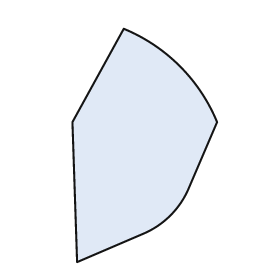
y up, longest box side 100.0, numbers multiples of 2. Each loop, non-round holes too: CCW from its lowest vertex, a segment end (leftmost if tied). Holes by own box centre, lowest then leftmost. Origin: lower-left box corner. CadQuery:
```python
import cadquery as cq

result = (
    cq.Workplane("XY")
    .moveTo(2.0, 0.0)
    .lineTo(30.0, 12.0)
    .threePointArc((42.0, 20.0), (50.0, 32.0))
    .lineTo(62.0, 60.0)
    .threePointArc((46.0, 84.0), (22.0, 100.0))
    .lineTo(0.0, 60.0)
    .close()
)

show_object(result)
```